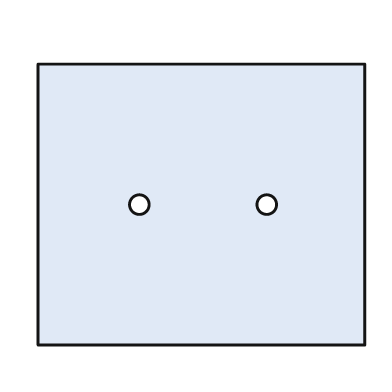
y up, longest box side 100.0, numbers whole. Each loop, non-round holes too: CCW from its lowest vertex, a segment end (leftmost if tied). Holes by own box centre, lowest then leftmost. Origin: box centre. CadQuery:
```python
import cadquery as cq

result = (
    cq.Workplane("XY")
    .moveTo(-50.0, -43.0)
    .lineTo(50.0, -43.0)
    .lineTo(50.0, 43.0)
    .lineTo(-50.0, 43.0)
    .close()
    .moveTo(-19.0, 0.0)
    .circle(3.0)
    .moveTo(20.0, 0.0)
    .circle(3.0)
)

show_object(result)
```